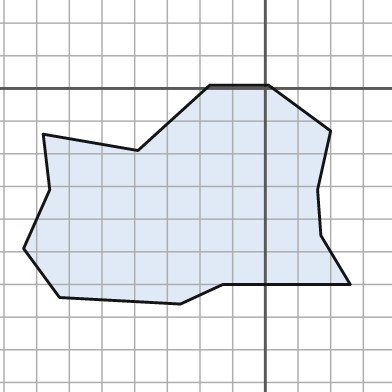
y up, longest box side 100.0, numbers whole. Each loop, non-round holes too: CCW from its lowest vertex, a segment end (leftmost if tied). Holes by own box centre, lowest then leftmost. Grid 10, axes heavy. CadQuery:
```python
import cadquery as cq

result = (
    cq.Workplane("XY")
    .moveTo(-26.0, -66.0)
    .lineTo(-13.0, -60.0)
    .lineTo(26.0, -60.0)
    .lineTo(17.0, -45.0)
    .lineTo(16.0, -31.0)
    .lineTo(20.0, -13.0)
    .lineTo(1.0, 1.0)
    .lineTo(-17.0, 1.0)
    .lineTo(-39.0, -19.0)
    .lineTo(-68.0, -14.0)
    .lineTo(-66.0, -31.0)
    .lineTo(-74.0, -49.0)
    .lineTo(-63.0, -64.0)
    .close()
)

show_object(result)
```